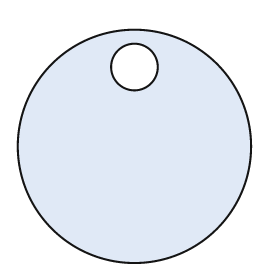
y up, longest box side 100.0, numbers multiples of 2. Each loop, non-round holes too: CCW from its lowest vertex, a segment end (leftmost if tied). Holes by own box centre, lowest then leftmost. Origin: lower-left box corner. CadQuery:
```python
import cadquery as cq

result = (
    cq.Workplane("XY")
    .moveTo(50.0, 50.0)
    .circle(50.0)
    .moveTo(50.0, 84.0)
    .circle(10.0)
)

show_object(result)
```